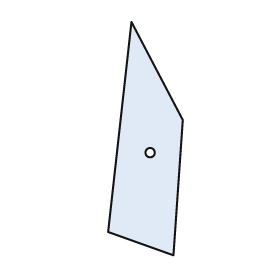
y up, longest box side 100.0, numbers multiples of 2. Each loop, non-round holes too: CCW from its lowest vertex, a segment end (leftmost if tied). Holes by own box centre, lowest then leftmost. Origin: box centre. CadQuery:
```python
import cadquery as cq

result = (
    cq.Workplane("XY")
    .moveTo(12.0, -50.0)
    .lineTo(16.0, 8.0)
    .lineTo(-6.0, 50.0)
    .lineTo(-16.0, -40.0)
    .close()
    .moveTo(2.0, -6.0)
    .circle(2.0)
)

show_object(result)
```